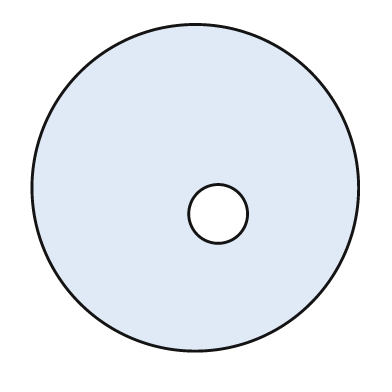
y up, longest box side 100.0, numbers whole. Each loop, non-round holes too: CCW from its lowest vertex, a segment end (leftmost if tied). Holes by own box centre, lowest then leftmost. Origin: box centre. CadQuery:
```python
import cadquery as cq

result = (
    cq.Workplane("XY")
    .moveTo(0.0, 0.0)
    .circle(50.0)
    .moveTo(7.0, -8.0)
    .circle(9.0)
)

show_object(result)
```